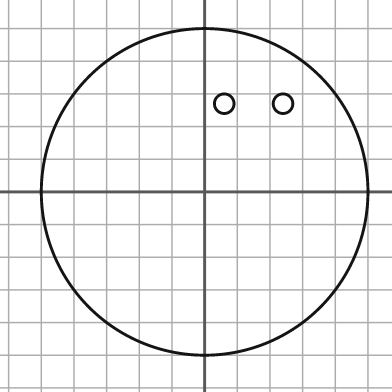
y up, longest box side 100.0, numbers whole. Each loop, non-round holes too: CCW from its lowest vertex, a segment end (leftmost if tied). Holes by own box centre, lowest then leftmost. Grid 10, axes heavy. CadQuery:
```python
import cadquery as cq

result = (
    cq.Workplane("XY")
    .moveTo(0.0, 0.0)
    .circle(50.0)
    .moveTo(6.0, 27.0)
    .circle(3.0)
    .moveTo(24.0, 27.0)
    .circle(3.0)
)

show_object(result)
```